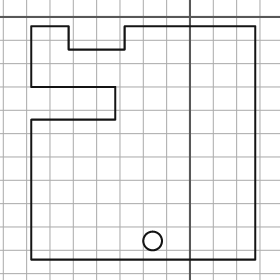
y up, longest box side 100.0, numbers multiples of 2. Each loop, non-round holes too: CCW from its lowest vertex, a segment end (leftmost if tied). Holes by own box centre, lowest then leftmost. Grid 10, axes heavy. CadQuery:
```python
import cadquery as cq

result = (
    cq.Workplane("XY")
    .moveTo(-68.0, -104.0)
    .lineTo(28.0, -104.0)
    .lineTo(28.0, -4.0)
    .lineTo(-28.0, -4.0)
    .lineTo(-28.0, -14.0)
    .lineTo(-52.0, -14.0)
    .lineTo(-52.0, -4.0)
    .lineTo(-68.0, -4.0)
    .lineTo(-68.0, -30.0)
    .lineTo(-32.0, -30.0)
    .lineTo(-32.0, -44.0)
    .lineTo(-68.0, -44.0)
    .close()
    .moveTo(-16.0, -96.0)
    .circle(4.0)
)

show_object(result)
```